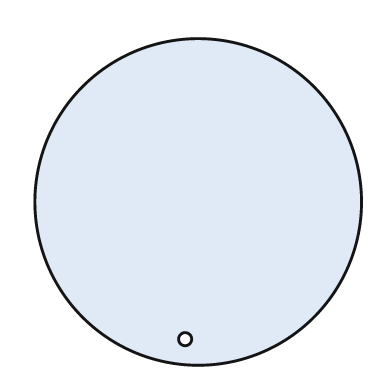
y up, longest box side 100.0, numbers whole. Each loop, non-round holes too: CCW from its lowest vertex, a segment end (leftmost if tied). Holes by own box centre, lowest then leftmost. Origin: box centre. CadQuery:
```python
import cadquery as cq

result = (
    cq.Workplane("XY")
    .moveTo(0.0, 0.0)
    .circle(50.0)
    .moveTo(-4.0, -42.0)
    .circle(2.0)
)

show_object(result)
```